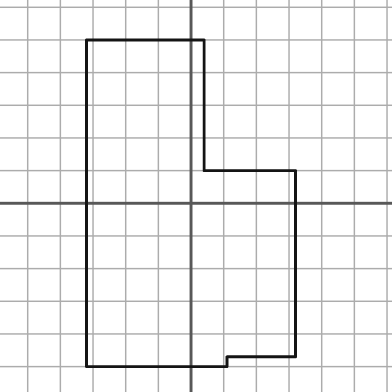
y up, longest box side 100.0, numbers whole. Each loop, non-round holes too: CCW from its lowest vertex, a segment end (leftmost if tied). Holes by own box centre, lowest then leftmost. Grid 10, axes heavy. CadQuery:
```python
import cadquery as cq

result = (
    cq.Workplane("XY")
    .moveTo(-32.0, -50.0)
    .lineTo(11.0, -50.0)
    .lineTo(11.0, -47.0)
    .lineTo(32.0, -47.0)
    .lineTo(32.0, 10.0)
    .lineTo(4.0, 10.0)
    .lineTo(4.0, 50.0)
    .lineTo(-32.0, 50.0)
    .close()
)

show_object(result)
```